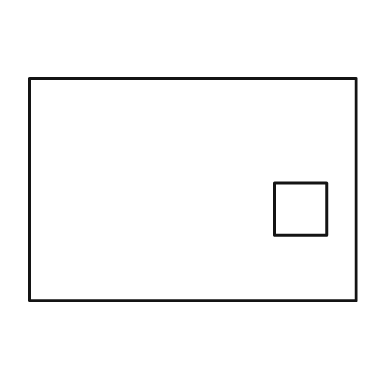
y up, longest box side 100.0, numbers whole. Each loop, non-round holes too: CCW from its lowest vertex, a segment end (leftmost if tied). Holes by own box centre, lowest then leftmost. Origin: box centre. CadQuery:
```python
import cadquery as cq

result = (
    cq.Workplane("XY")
    .moveTo(-50.0, -34.0)
    .lineTo(50.0, -34.0)
    .lineTo(50.0, 34.0)
    .lineTo(-50.0, 34.0)
    .close()
    .moveTo(25.0, -14.0)
    .lineTo(41.0, -14.0)
    .lineTo(41.0, 2.0)
    .lineTo(25.0, 2.0)
    .close()
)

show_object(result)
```